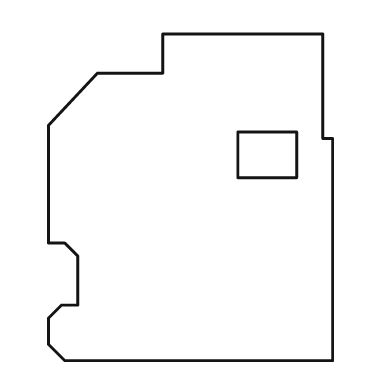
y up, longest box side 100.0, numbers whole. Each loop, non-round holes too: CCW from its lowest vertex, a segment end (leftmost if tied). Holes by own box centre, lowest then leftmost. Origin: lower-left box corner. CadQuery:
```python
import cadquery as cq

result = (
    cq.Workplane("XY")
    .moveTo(5.0, 0.0)
    .lineTo(87.0, 0.0)
    .lineTo(87.0, 68.0)
    .lineTo(84.0, 68.0)
    .lineTo(84.0, 100.0)
    .lineTo(35.0, 100.0)
    .lineTo(35.0, 88.0)
    .lineTo(15.0, 88.0)
    .lineTo(0.0, 72.0)
    .lineTo(0.0, 36.0)
    .lineTo(5.0, 36.0)
    .lineTo(9.0, 32.0)
    .lineTo(9.0, 17.0)
    .lineTo(4.0, 17.0)
    .lineTo(0.0, 13.0)
    .lineTo(0.0, 5.0)
    .close()
    .moveTo(58.0, 56.0)
    .lineTo(76.0, 56.0)
    .lineTo(76.0, 70.0)
    .lineTo(58.0, 70.0)
    .close()
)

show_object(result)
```